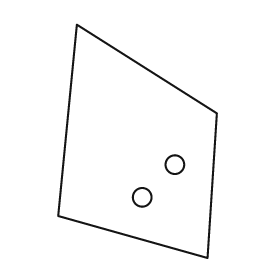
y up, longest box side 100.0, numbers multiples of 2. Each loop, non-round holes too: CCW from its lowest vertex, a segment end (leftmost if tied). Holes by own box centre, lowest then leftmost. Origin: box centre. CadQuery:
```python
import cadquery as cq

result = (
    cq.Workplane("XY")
    .moveTo(30.0, -50.0)
    .lineTo(34.0, 12.0)
    .lineTo(-26.0, 50.0)
    .lineTo(-34.0, -32.0)
    .close()
    .moveTo(2.0, -24.0)
    .circle(4.0)
    .moveTo(16.0, -10.0)
    .circle(4.0)
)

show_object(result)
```